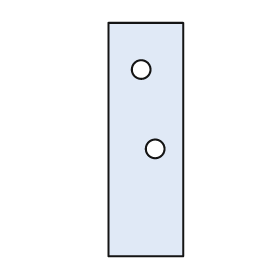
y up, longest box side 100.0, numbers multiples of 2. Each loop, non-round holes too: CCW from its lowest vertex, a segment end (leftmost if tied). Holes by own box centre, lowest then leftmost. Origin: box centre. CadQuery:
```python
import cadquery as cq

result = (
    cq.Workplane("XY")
    .moveTo(-16.0, -50.0)
    .lineTo(16.0, -50.0)
    .lineTo(16.0, 50.0)
    .lineTo(-16.0, 50.0)
    .close()
    .moveTo(4.0, -4.0)
    .circle(4.0)
    .moveTo(-2.0, 30.0)
    .circle(4.0)
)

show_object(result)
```